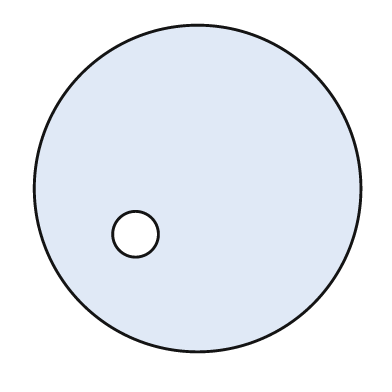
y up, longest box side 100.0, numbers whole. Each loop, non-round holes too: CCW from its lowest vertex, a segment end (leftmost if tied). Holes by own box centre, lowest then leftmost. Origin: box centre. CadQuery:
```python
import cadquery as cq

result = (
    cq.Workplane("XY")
    .moveTo(0.0, 0.0)
    .circle(50.0)
    .moveTo(-19.0, -14.0)
    .circle(7.0)
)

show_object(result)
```